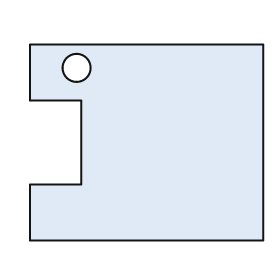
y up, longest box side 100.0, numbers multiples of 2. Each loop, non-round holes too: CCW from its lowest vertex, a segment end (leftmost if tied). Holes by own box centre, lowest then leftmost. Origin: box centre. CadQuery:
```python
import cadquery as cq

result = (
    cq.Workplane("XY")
    .moveTo(-50.0, -42.0)
    .lineTo(50.0, -42.0)
    .lineTo(50.0, 42.0)
    .lineTo(-50.0, 42.0)
    .lineTo(-50.0, 18.0)
    .lineTo(-28.0, 18.0)
    .lineTo(-28.0, -18.0)
    .lineTo(-50.0, -18.0)
    .close()
    .moveTo(-30.0, 32.0)
    .circle(6.0)
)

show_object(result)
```